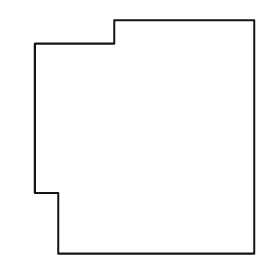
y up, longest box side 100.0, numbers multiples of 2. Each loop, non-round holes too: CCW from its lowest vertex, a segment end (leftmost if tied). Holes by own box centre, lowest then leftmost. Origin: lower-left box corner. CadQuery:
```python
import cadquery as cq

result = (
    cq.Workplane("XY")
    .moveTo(10.0, 0.0)
    .lineTo(94.0, 0.0)
    .lineTo(94.0, 100.0)
    .lineTo(34.0, 100.0)
    .lineTo(34.0, 90.0)
    .lineTo(0.0, 90.0)
    .lineTo(0.0, 26.0)
    .lineTo(10.0, 26.0)
    .close()
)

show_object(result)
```